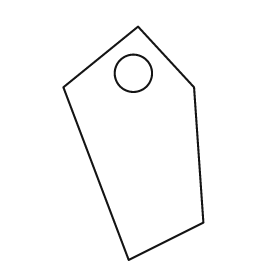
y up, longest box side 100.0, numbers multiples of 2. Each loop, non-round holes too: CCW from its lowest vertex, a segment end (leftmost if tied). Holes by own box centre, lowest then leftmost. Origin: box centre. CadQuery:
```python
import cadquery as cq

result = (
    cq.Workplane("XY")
    .moveTo(-2.0, -50.0)
    .lineTo(30.0, -34.0)
    .lineTo(26.0, 24.0)
    .lineTo(2.0, 50.0)
    .lineTo(-30.0, 24.0)
    .close()
    .moveTo(0.0, 30.0)
    .circle(8.0)
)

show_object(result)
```